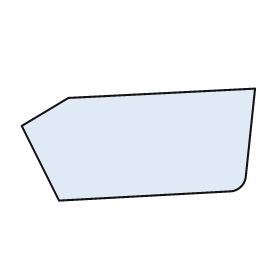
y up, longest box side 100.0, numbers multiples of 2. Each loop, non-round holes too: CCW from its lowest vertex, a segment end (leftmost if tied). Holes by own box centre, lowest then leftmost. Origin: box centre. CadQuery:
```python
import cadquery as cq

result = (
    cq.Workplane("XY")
    .moveTo(-34.0, -24.0)
    .lineTo(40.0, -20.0)
    .threePointArc((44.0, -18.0), (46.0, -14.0))
    .lineTo(50.0, 24.0)
    .lineTo(-30.0, 20.0)
    .lineTo(-50.0, 8.0)
    .close()
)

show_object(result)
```